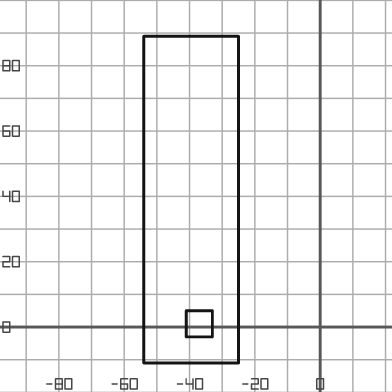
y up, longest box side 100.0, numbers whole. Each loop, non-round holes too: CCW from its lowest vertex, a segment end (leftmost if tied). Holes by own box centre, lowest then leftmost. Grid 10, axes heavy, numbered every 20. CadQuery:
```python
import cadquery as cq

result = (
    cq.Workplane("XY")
    .moveTo(-54.0, -11.0)
    .lineTo(-25.0, -11.0)
    .lineTo(-25.0, 89.0)
    .lineTo(-54.0, 89.0)
    .close()
    .moveTo(-41.0, -3.0)
    .lineTo(-33.0, -3.0)
    .lineTo(-33.0, 5.0)
    .lineTo(-41.0, 5.0)
    .close()
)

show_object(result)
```